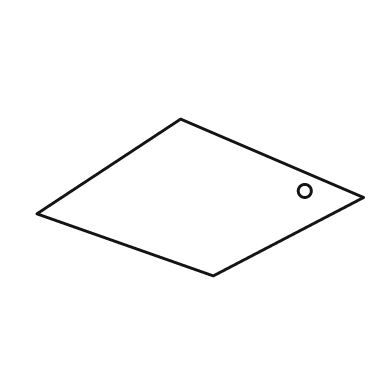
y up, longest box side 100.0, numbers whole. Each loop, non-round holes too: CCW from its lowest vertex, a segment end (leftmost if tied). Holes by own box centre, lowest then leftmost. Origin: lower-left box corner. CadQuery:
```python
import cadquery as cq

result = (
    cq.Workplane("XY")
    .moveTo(54.0, 0.0)
    .lineTo(100.0, 24.0)
    .lineTo(44.0, 48.0)
    .lineTo(0.0, 19.0)
    .close()
    .moveTo(82.0, 26.0)
    .circle(2.0)
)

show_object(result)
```